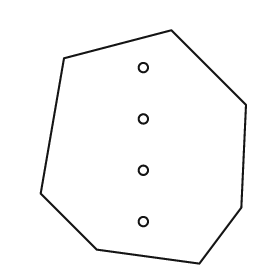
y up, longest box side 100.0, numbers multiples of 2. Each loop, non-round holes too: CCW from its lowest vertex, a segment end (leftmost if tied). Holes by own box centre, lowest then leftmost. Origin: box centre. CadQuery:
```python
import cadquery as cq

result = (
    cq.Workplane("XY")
    .moveTo(24.0, -50.0)
    .lineTo(42.0, -26.0)
    .lineTo(44.0, 18.0)
    .lineTo(12.0, 50.0)
    .lineTo(-34.0, 38.0)
    .lineTo(-44.0, -20.0)
    .lineTo(-20.0, -44.0)
    .close()
    .moveTo(0.0, -32.0)
    .circle(2.0)
    .moveTo(0.0, -10.0)
    .circle(2.0)
    .moveTo(0.0, 12.0)
    .circle(2.0)
    .moveTo(0.0, 34.0)
    .circle(2.0)
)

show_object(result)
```